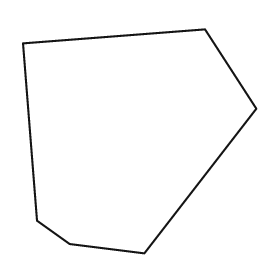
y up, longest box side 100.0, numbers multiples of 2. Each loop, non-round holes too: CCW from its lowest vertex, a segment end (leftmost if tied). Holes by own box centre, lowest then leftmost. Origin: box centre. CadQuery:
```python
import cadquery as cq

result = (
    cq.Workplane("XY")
    .moveTo(2.0, -48.0)
    .lineTo(50.0, 14.0)
    .lineTo(28.0, 48.0)
    .lineTo(-50.0, 42.0)
    .lineTo(-44.0, -34.0)
    .lineTo(-30.0, -44.0)
    .close()
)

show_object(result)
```